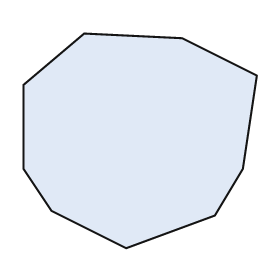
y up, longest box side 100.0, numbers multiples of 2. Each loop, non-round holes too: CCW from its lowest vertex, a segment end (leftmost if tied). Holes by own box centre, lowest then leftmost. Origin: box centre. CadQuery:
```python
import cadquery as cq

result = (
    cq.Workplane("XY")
    .moveTo(-6.0, -46.0)
    .lineTo(32.0, -32.0)
    .lineTo(44.0, -12.0)
    .lineTo(50.0, 28.0)
    .lineTo(18.0, 44.0)
    .lineTo(-24.0, 46.0)
    .lineTo(-50.0, 24.0)
    .lineTo(-50.0, -12.0)
    .lineTo(-38.0, -30.0)
    .close()
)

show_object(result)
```